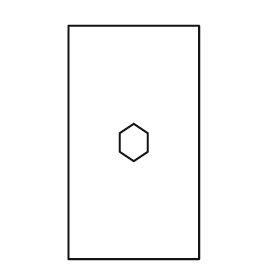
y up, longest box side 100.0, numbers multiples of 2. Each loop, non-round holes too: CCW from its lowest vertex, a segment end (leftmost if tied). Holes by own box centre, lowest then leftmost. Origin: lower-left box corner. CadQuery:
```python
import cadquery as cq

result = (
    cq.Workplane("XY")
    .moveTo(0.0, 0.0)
    .lineTo(56.0, 0.0)
    .lineTo(56.0, 100.0)
    .lineTo(0.0, 100.0)
    .close()
    .moveTo(28.0, 42.0)
    .lineTo(34.0, 46.0)
    .lineTo(34.0, 54.0)
    .lineTo(28.0, 58.0)
    .lineTo(22.0, 54.0)
    .lineTo(22.0, 46.0)
    .close()
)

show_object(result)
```